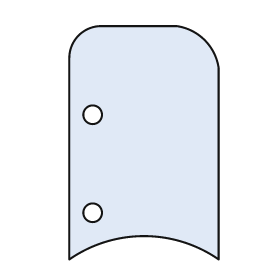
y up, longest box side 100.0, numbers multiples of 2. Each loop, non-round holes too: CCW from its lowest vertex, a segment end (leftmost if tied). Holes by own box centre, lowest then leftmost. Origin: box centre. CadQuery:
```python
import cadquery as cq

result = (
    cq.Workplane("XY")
    .moveTo(-32.0, -50.0)
    .threePointArc((0.0, -40.0), (32.0, -50.0))
    .lineTo(32.0, 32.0)
    .threePointArc((26.0, 44.0), (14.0, 50.0))
    .lineTo(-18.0, 50.0)
    .threePointArc((-28.0, 46.0), (-32.0, 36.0))
    .close()
    .moveTo(-22.0, -30.0)
    .circle(4.0)
    .moveTo(-22.0, 12.0)
    .circle(4.0)
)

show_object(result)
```